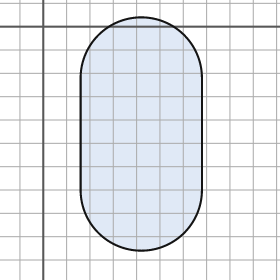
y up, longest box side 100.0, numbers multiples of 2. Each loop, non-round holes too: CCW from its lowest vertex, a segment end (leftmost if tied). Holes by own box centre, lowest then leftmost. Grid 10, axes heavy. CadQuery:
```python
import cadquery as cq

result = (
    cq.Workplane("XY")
    .moveTo(16.0, -70.0)
    .threePointArc((42.0, -96.0), (68.0, -70.0))
    .lineTo(68.0, -22.0)
    .threePointArc((42.0, 4.0), (16.0, -22.0))
    .close()
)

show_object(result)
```